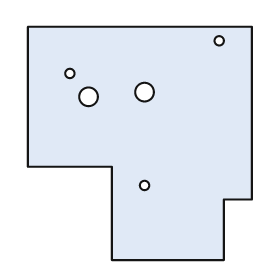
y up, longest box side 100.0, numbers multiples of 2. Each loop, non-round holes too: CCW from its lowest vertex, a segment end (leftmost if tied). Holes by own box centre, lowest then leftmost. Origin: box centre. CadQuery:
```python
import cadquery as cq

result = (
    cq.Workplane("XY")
    .moveTo(-12.0, -50.0)
    .lineTo(36.0, -50.0)
    .lineTo(36.0, -24.0)
    .lineTo(48.0, -24.0)
    .lineTo(48.0, 50.0)
    .lineTo(-48.0, 50.0)
    .lineTo(-48.0, -10.0)
    .lineTo(-12.0, -10.0)
    .close()
    .moveTo(2.0, -18.0)
    .circle(2.0)
    .moveTo(-22.0, 20.0)
    .circle(4.0)
    .moveTo(2.0, 22.0)
    .circle(4.0)
    .moveTo(-30.0, 30.0)
    .circle(2.0)
    .moveTo(34.0, 44.0)
    .circle(2.0)
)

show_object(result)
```